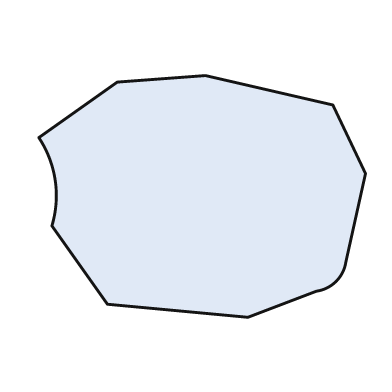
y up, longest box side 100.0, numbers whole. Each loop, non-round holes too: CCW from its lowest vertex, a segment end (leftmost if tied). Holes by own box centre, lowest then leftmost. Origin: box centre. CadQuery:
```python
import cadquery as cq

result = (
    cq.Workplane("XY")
    .moveTo(14.0, -37.0)
    .lineTo(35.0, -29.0)
    .threePointArc((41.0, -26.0), (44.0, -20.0))
    .lineTo(50.0, 7.0)
    .lineTo(40.0, 28.0)
    .lineTo(1.0, 37.0)
    .lineTo(-26.0, 35.0)
    .lineTo(-50.0, 18.0)
    .threePointArc((-45.0, 5.0), (-46.0, -9.0))
    .lineTo(-29.0, -33.0)
    .close()
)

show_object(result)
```